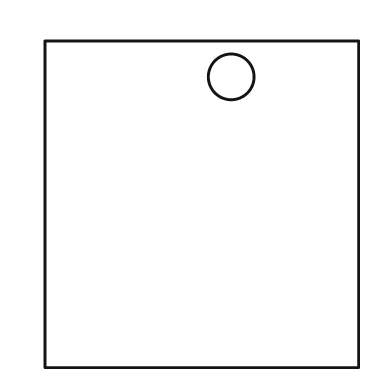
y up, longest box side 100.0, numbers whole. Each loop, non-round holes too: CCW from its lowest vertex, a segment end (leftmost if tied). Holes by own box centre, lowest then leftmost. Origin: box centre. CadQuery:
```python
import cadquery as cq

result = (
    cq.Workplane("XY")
    .moveTo(-48.0, -50.0)
    .lineTo(48.0, -50.0)
    .lineTo(48.0, 50.0)
    .lineTo(-48.0, 50.0)
    .close()
    .moveTo(9.0, 39.0)
    .circle(7.0)
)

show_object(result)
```